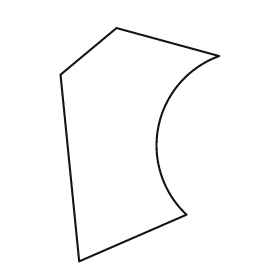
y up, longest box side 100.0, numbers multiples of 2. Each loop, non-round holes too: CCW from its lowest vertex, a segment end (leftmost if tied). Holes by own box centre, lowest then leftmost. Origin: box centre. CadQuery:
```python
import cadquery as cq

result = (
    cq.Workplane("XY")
    .moveTo(-26.0, -50.0)
    .lineTo(20.0, -30.0)
    .threePointArc((8.0, 8.0), (34.0, 38.0))
    .lineTo(-10.0, 50.0)
    .lineTo(-34.0, 30.0)
    .close()
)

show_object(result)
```